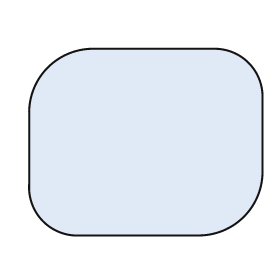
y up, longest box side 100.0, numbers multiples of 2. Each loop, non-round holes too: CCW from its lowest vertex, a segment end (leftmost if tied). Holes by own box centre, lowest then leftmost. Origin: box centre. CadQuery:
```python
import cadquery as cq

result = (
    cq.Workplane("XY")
    .moveTo(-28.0, -40.0)
    .lineTo(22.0, -40.0)
    .threePointArc((42.0, -32.0), (50.0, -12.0))
    .lineTo(50.0, 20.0)
    .threePointArc((44.0, 34.0), (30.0, 40.0))
    .lineTo(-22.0, 40.0)
    .threePointArc((-42.0, 32.0), (-50.0, 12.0))
    .lineTo(-50.0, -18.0)
    .threePointArc((-44.0, -34.0), (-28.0, -40.0))
    .close()
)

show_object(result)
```